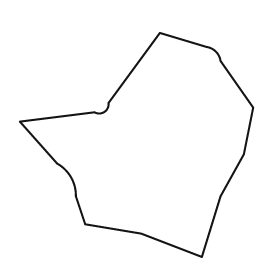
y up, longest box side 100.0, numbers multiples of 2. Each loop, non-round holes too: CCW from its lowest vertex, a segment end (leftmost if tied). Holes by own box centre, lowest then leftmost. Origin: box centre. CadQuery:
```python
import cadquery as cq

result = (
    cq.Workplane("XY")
    .moveTo(28.0, -48.0)
    .lineTo(36.0, -22.0)
    .lineTo(46.0, -4.0)
    .lineTo(50.0, 16.0)
    .lineTo(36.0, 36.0)
    .threePointArc((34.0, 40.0), (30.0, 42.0))
    .lineTo(10.0, 48.0)
    .lineTo(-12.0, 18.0)
    .threePointArc((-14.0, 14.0), (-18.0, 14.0))
    .lineTo(-50.0, 10.0)
    .lineTo(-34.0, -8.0)
    .threePointArc((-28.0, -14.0), (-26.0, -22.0))
    .lineTo(-22.0, -34.0)
    .lineTo(2.0, -38.0)
    .close()
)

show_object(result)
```